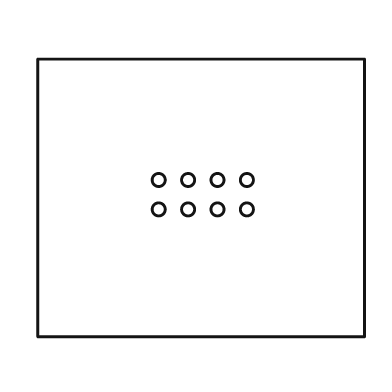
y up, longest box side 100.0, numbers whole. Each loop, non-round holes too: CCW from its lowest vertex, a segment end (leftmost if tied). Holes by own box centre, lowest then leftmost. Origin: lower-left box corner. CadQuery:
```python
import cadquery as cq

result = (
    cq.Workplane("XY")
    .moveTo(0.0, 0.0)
    .lineTo(100.0, 0.0)
    .lineTo(100.0, 85.0)
    .lineTo(0.0, 85.0)
    .close()
    .moveTo(37.0, 39.0)
    .circle(2.0)
    .moveTo(46.0, 39.0)
    .circle(2.0)
    .moveTo(55.0, 39.0)
    .circle(2.0)
    .moveTo(64.0, 39.0)
    .circle(2.0)
    .moveTo(37.0, 48.0)
    .circle(2.0)
    .moveTo(46.0, 48.0)
    .circle(2.0)
    .moveTo(55.0, 48.0)
    .circle(2.0)
    .moveTo(64.0, 48.0)
    .circle(2.0)
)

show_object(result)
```